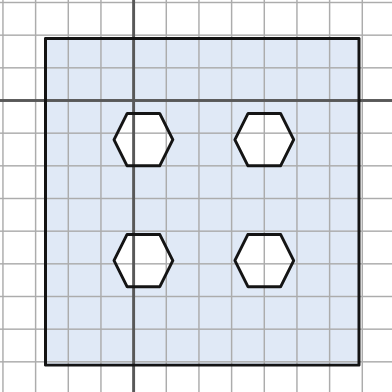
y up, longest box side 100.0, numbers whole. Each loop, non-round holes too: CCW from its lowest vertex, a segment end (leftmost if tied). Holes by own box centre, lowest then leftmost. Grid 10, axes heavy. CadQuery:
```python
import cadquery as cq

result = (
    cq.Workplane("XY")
    .moveTo(-27.0, -81.0)
    .lineTo(69.0, -81.0)
    .lineTo(69.0, 19.0)
    .lineTo(-27.0, 19.0)
    .close()
    .moveTo(-2.0, -57.0)
    .lineTo(8.0, -57.0)
    .lineTo(12.0, -49.0)
    .lineTo(8.0, -41.0)
    .lineTo(-2.0, -41.0)
    .lineTo(-6.0, -49.0)
    .close()
    .moveTo(35.0, -57.0)
    .lineTo(45.0, -57.0)
    .lineTo(49.0, -49.0)
    .lineTo(45.0, -41.0)
    .lineTo(35.0, -41.0)
    .lineTo(31.0, -49.0)
    .close()
    .moveTo(-2.0, -20.0)
    .lineTo(8.0, -20.0)
    .lineTo(12.0, -12.0)
    .lineTo(8.0, -4.0)
    .lineTo(-2.0, -4.0)
    .lineTo(-6.0, -12.0)
    .close()
    .moveTo(35.0, -20.0)
    .lineTo(45.0, -20.0)
    .lineTo(49.0, -12.0)
    .lineTo(45.0, -4.0)
    .lineTo(35.0, -4.0)
    .lineTo(31.0, -12.0)
    .close()
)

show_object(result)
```